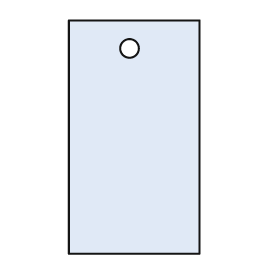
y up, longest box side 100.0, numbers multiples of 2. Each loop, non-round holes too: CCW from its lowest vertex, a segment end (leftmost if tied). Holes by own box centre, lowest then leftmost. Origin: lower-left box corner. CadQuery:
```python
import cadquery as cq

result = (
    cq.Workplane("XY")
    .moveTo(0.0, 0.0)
    .lineTo(56.0, 0.0)
    .lineTo(56.0, 100.0)
    .lineTo(0.0, 100.0)
    .close()
    .moveTo(26.0, 88.0)
    .circle(4.0)
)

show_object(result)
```